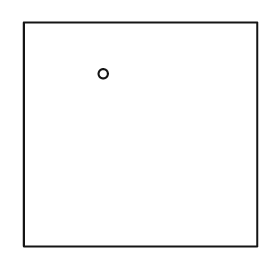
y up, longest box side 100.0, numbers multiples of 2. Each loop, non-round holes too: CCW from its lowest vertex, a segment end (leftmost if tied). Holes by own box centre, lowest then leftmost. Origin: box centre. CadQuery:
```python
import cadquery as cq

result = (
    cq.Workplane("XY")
    .moveTo(-50.0, -48.0)
    .lineTo(50.0, -48.0)
    .lineTo(50.0, 48.0)
    .lineTo(-50.0, 48.0)
    .close()
    .moveTo(-16.0, 26.0)
    .circle(2.0)
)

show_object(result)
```